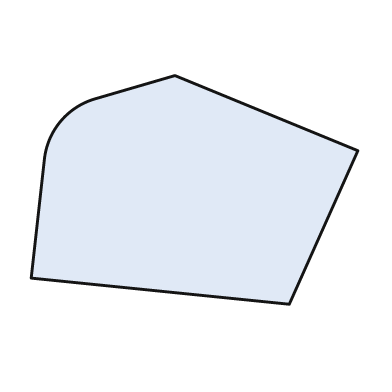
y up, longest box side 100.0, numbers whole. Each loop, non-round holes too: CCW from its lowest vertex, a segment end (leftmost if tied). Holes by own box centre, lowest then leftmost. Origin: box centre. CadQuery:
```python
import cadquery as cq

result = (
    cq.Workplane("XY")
    .moveTo(29.0, -35.0)
    .lineTo(50.0, 12.0)
    .lineTo(-6.0, 35.0)
    .lineTo(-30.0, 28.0)
    .threePointArc((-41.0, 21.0), (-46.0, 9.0))
    .lineTo(-50.0, -27.0)
    .close()
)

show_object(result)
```